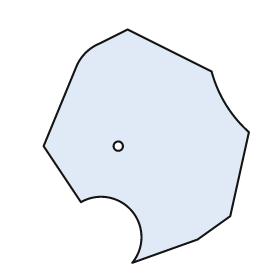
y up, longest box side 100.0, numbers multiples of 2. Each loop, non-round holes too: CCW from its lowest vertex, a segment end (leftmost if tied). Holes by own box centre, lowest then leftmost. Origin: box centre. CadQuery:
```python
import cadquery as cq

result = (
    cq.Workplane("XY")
    .moveTo(-6.0, -50.0)
    .lineTo(22.0, -40.0)
    .lineTo(36.0, -30.0)
    .lineTo(44.0, 6.0)
    .threePointArc((34.0, 18.0), (28.0, 32.0))
    .lineTo(-8.0, 50.0)
    .lineTo(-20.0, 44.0)
    .threePointArc((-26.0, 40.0), (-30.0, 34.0))
    .lineTo(-44.0, 0.0)
    .lineTo(-28.0, -24.0)
    .threePointArc((-6.0, -28.0), (-6.0, -50.0))
    .close()
    .moveTo(-12.0, 0.0)
    .circle(2.0)
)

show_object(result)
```